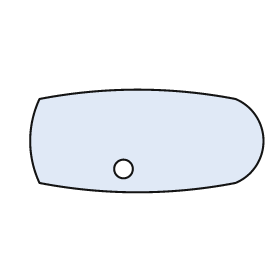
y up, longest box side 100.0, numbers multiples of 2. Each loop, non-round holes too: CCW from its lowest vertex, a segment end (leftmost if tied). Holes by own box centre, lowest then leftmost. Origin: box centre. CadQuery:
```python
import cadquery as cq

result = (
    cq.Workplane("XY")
    .moveTo(-46.0, -18.0)
    .threePointArc((-4.0, -22.0), (38.0, -18.0))
    .threePointArc((50.0, 0.0), (38.0, 18.0))
    .threePointArc((-4.0, 22.0), (-46.0, 18.0))
    .threePointArc((-50.0, 0.0), (-46.0, -18.0))
    .close()
    .moveTo(-10.0, -12.0)
    .circle(4.0)
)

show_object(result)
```